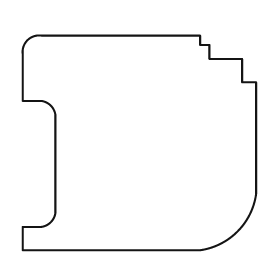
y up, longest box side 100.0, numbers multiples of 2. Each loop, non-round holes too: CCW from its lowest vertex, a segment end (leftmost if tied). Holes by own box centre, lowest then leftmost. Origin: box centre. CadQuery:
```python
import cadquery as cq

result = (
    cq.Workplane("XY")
    .moveTo(-50.0, -46.0)
    .lineTo(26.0, -46.0)
    .threePointArc((42.0, -38.0), (50.0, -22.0))
    .lineTo(50.0, 26.0)
    .lineTo(44.0, 26.0)
    .lineTo(44.0, 36.0)
    .lineTo(30.0, 36.0)
    .lineTo(30.0, 42.0)
    .lineTo(26.0, 42.0)
    .lineTo(26.0, 46.0)
    .lineTo(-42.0, 46.0)
    .threePointArc((-48.0, 44.0), (-50.0, 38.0))
    .lineTo(-50.0, 18.0)
    .lineTo(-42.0, 18.0)
    .threePointArc((-38.0, 16.0), (-36.0, 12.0))
    .lineTo(-36.0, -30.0)
    .threePointArc((-38.0, -34.0), (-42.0, -36.0))
    .lineTo(-50.0, -36.0)
    .close()
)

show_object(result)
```